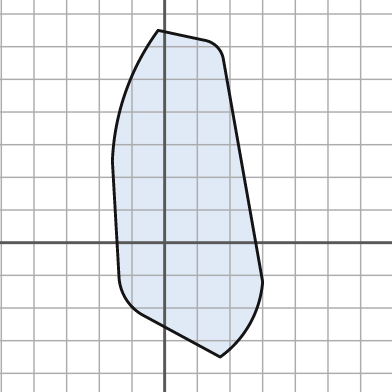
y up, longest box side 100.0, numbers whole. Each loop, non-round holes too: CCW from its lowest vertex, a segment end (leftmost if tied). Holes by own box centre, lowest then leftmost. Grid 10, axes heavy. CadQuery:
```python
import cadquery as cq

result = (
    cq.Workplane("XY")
    .moveTo(17.0, -35.0)
    .threePointArc((26.0, -25.0), (30.0, -12.0))
    .lineTo(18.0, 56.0)
    .threePointArc((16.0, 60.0), (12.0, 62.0))
    .lineTo(-2.0, 65.0)
    .threePointArc((-12.0, 46.0), (-16.0, 25.0))
    .lineTo(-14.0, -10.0)
    .threePointArc((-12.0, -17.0), (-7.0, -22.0))
    .close()
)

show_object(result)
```